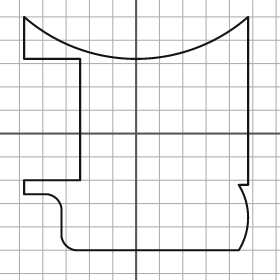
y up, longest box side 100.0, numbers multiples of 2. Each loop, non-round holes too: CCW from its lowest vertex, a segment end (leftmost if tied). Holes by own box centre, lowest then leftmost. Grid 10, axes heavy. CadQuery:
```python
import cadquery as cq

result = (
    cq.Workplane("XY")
    .moveTo(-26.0, -50.0)
    .lineTo(44.0, -50.0)
    .threePointArc((48.0, -36.0), (44.0, -22.0))
    .lineTo(48.0, -22.0)
    .lineTo(48.0, 50.0)
    .threePointArc((0.0, 32.0), (-48.0, 50.0))
    .lineTo(-48.0, 32.0)
    .lineTo(-24.0, 32.0)
    .lineTo(-24.0, -20.0)
    .lineTo(-48.0, -20.0)
    .lineTo(-48.0, -26.0)
    .lineTo(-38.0, -26.0)
    .threePointArc((-34.0, -28.0), (-32.0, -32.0))
    .lineTo(-32.0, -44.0)
    .threePointArc((-30.0, -48.0), (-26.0, -50.0))
    .close()
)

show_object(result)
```